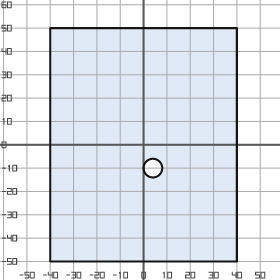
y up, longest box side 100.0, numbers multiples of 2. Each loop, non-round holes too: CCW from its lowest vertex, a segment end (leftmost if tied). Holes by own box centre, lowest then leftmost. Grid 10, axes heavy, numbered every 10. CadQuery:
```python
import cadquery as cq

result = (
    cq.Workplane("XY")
    .moveTo(-40.0, -50.0)
    .lineTo(40.0, -50.0)
    .lineTo(40.0, 50.0)
    .lineTo(-40.0, 50.0)
    .close()
    .moveTo(4.0, -10.0)
    .circle(4.0)
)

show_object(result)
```